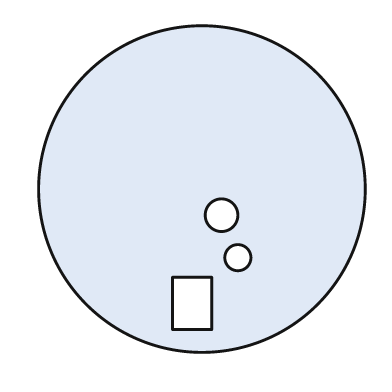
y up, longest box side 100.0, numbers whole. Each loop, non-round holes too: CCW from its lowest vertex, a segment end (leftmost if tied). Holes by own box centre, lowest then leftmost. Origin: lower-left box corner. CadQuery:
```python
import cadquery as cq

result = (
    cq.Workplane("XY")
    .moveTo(50.0, 50.0)
    .circle(50.0)
    .moveTo(41.0, 7.0)
    .lineTo(53.0, 7.0)
    .lineTo(53.0, 23.0)
    .lineTo(41.0, 23.0)
    .close()
    .moveTo(61.0, 29.0)
    .circle(4.0)
    .moveTo(56.0, 42.0)
    .circle(5.0)
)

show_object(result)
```